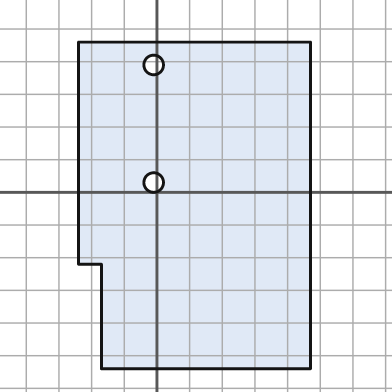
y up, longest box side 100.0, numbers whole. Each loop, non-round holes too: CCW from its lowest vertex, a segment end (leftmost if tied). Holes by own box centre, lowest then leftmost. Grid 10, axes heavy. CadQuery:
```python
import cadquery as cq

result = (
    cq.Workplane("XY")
    .moveTo(-17.0, -54.0)
    .lineTo(47.0, -54.0)
    .lineTo(47.0, 46.0)
    .lineTo(-24.0, 46.0)
    .lineTo(-24.0, -22.0)
    .lineTo(-17.0, -22.0)
    .close()
    .moveTo(-1.0, 3.0)
    .circle(3.0)
    .moveTo(-1.0, 39.0)
    .circle(3.0)
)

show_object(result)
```